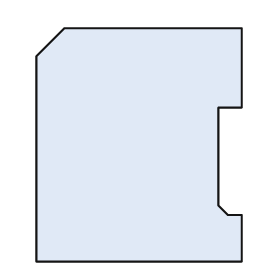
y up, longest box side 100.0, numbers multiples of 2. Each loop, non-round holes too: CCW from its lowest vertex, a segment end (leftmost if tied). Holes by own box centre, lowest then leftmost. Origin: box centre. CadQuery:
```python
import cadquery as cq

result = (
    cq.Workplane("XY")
    .moveTo(-44.0, -50.0)
    .lineTo(44.0, -50.0)
    .lineTo(44.0, -30.0)
    .lineTo(38.0, -30.0)
    .lineTo(34.0, -26.0)
    .lineTo(34.0, 16.0)
    .lineTo(44.0, 16.0)
    .lineTo(44.0, 50.0)
    .lineTo(-32.0, 50.0)
    .lineTo(-44.0, 38.0)
    .close()
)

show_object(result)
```